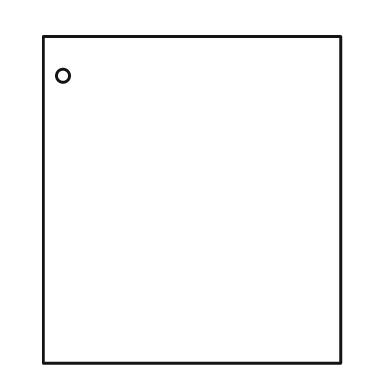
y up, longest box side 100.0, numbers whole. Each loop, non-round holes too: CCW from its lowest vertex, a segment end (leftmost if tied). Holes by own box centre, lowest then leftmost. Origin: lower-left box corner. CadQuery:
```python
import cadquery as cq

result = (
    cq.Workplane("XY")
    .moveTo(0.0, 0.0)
    .lineTo(91.0, 0.0)
    .lineTo(91.0, 100.0)
    .lineTo(0.0, 100.0)
    .close()
    .moveTo(6.0, 88.0)
    .circle(2.0)
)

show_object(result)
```